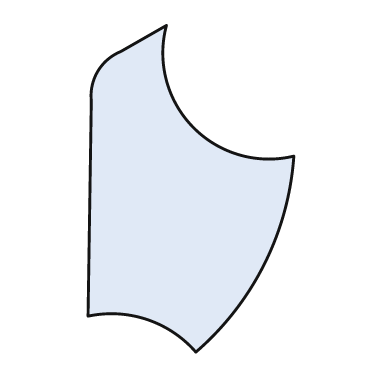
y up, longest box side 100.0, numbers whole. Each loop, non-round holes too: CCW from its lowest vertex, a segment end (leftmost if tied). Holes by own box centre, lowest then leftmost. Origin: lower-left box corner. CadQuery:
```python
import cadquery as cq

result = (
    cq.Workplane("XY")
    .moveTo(33.0, 0.0)
    .threePointArc((54.0, 27.0), (63.0, 60.0))
    .threePointArc((32.0, 69.0), (24.0, 100.0))
    .lineTo(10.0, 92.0)
    .threePointArc((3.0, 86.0), (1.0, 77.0))
    .lineTo(0.0, 11.0)
    .threePointArc((18.0, 10.0), (33.0, 0.0))
    .close()
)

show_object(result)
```